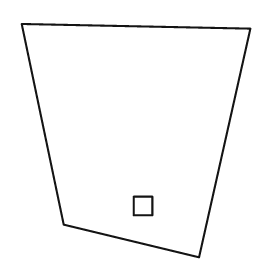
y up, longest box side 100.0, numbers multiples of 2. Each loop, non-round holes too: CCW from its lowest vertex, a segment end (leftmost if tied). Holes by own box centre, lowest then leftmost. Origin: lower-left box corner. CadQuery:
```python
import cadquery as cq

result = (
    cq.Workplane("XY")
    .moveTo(76.0, 0.0)
    .lineTo(98.0, 98.0)
    .lineTo(0.0, 100.0)
    .lineTo(18.0, 14.0)
    .close()
    .moveTo(48.0, 18.0)
    .lineTo(56.0, 18.0)
    .lineTo(56.0, 26.0)
    .lineTo(48.0, 26.0)
    .close()
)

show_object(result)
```